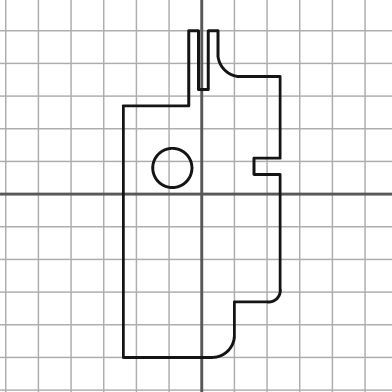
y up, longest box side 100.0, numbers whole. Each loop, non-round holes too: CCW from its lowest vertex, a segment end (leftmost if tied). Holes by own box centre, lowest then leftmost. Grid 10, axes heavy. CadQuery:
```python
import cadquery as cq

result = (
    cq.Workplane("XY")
    .moveTo(-24.0, -50.0)
    .lineTo(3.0, -50.0)
    .threePointArc((8.0, -48.0), (10.0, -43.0))
    .lineTo(10.0, -33.0)
    .lineTo(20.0, -33.0)
    .threePointArc((23.0, -32.0), (24.0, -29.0))
    .lineTo(24.0, 6.0)
    .lineTo(16.0, 6.0)
    .lineTo(16.0, 11.0)
    .lineTo(24.0, 11.0)
    .lineTo(24.0, 36.0)
    .lineTo(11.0, 36.0)
    .threePointArc((7.0, 38.0), (5.0, 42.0))
    .lineTo(5.0, 50.0)
    .lineTo(2.0, 50.0)
    .lineTo(2.0, 32.0)
    .lineTo(-1.0, 32.0)
    .lineTo(-1.0, 50.0)
    .lineTo(-4.0, 50.0)
    .lineTo(-4.0, 27.0)
    .lineTo(-24.0, 27.0)
    .close()
    .moveTo(-9.0, 8.0)
    .circle(6.0)
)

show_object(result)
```